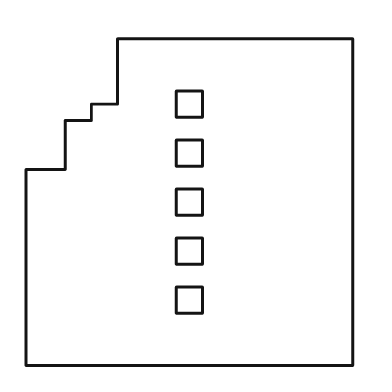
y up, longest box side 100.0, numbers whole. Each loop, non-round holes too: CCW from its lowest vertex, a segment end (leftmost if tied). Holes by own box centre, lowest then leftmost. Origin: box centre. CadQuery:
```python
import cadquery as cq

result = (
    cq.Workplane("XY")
    .moveTo(-50.0, -50.0)
    .lineTo(50.0, -50.0)
    .lineTo(50.0, 50.0)
    .lineTo(-22.0, 50.0)
    .lineTo(-22.0, 30.0)
    .lineTo(-30.0, 30.0)
    .lineTo(-30.0, 25.0)
    .lineTo(-38.0, 25.0)
    .lineTo(-38.0, 10.0)
    .lineTo(-50.0, 10.0)
    .close()
    .moveTo(-4.0, -34.0)
    .lineTo(4.0, -34.0)
    .lineTo(4.0, -26.0)
    .lineTo(-4.0, -26.0)
    .close()
    .moveTo(-4.0, -19.0)
    .lineTo(4.0, -19.0)
    .lineTo(4.0, -11.0)
    .lineTo(-4.0, -11.0)
    .close()
    .moveTo(-4.0, -4.0)
    .lineTo(4.0, -4.0)
    .lineTo(4.0, 4.0)
    .lineTo(-4.0, 4.0)
    .close()
    .moveTo(-4.0, 11.0)
    .lineTo(4.0, 11.0)
    .lineTo(4.0, 19.0)
    .lineTo(-4.0, 19.0)
    .close()
    .moveTo(-4.0, 26.0)
    .lineTo(4.0, 26.0)
    .lineTo(4.0, 34.0)
    .lineTo(-4.0, 34.0)
    .close()
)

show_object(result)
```